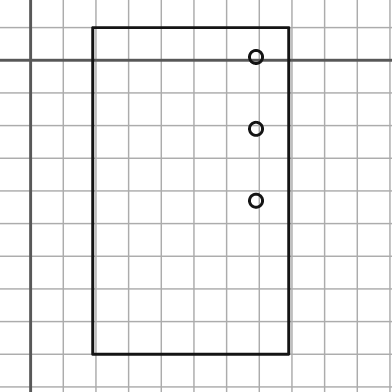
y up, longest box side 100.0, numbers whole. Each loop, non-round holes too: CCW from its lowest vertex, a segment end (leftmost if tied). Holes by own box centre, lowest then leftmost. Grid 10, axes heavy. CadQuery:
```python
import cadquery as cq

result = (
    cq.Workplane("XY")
    .moveTo(19.0, -90.0)
    .lineTo(79.0, -90.0)
    .lineTo(79.0, 10.0)
    .lineTo(19.0, 10.0)
    .close()
    .moveTo(69.0, -43.0)
    .circle(2.0)
    .moveTo(69.0, -21.0)
    .circle(2.0)
    .moveTo(69.0, 1.0)
    .circle(2.0)
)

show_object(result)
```